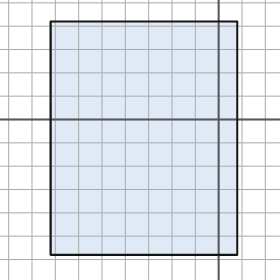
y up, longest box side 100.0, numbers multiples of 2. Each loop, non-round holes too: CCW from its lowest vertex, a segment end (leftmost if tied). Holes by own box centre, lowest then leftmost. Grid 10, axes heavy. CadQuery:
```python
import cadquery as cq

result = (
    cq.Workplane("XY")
    .moveTo(-72.0, -58.0)
    .lineTo(8.0, -58.0)
    .lineTo(8.0, 42.0)
    .lineTo(-72.0, 42.0)
    .close()
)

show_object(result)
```